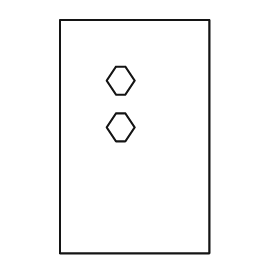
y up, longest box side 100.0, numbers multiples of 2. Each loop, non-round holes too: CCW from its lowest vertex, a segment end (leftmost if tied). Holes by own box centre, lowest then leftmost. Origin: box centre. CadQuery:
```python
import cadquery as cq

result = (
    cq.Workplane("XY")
    .moveTo(-32.0, -50.0)
    .lineTo(32.0, -50.0)
    .lineTo(32.0, 50.0)
    .lineTo(-32.0, 50.0)
    .close()
    .moveTo(-8.0, -2.0)
    .lineTo(-4.0, -2.0)
    .lineTo(0.0, 4.0)
    .lineTo(-4.0, 10.0)
    .lineTo(-8.0, 10.0)
    .lineTo(-12.0, 4.0)
    .close()
    .moveTo(-8.0, 18.0)
    .lineTo(-4.0, 18.0)
    .lineTo(0.0, 24.0)
    .lineTo(-4.0, 30.0)
    .lineTo(-8.0, 30.0)
    .lineTo(-12.0, 24.0)
    .close()
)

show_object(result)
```